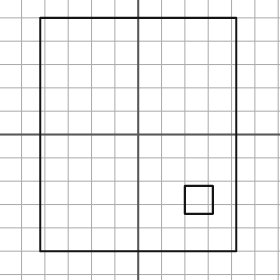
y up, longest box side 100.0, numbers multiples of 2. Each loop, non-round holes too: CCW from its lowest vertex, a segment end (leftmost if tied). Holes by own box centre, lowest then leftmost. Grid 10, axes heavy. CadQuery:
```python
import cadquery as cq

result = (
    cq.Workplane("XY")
    .moveTo(-42.0, -50.0)
    .lineTo(42.0, -50.0)
    .lineTo(42.0, 50.0)
    .lineTo(-42.0, 50.0)
    .close()
    .moveTo(20.0, -34.0)
    .lineTo(32.0, -34.0)
    .lineTo(32.0, -22.0)
    .lineTo(20.0, -22.0)
    .close()
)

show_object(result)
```